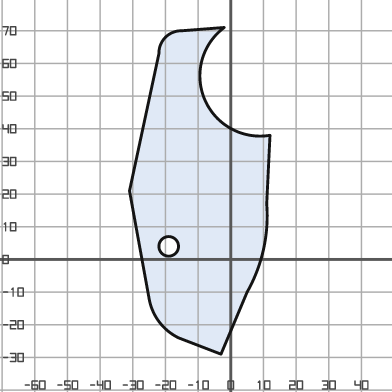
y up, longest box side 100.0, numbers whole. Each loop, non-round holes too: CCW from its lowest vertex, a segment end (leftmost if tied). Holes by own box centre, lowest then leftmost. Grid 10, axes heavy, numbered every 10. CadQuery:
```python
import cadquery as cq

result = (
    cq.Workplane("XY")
    .moveTo(-3.0, -29.0)
    .lineTo(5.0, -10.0)
    .threePointArc((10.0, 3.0), (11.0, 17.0))
    .lineTo(12.0, 38.0)
    .threePointArc((-8.0, 49.0), (-2.0, 71.0))
    .lineTo(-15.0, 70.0)
    .threePointArc((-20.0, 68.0), (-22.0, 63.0))
    .lineTo(-31.0, 21.0)
    .lineTo(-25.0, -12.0)
    .threePointArc((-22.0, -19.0), (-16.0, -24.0))
    .close()
    .moveTo(-19.0, 4.0)
    .circle(3.0)
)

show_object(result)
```